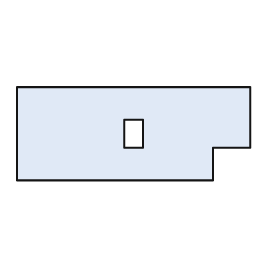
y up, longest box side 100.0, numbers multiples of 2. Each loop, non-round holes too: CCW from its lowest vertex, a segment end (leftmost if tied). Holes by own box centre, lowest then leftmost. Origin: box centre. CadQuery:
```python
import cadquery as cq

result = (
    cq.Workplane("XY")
    .moveTo(-50.0, -20.0)
    .lineTo(34.0, -20.0)
    .lineTo(34.0, -6.0)
    .lineTo(50.0, -6.0)
    .lineTo(50.0, 20.0)
    .lineTo(-50.0, 20.0)
    .close()
    .moveTo(-4.0, -6.0)
    .lineTo(4.0, -6.0)
    .lineTo(4.0, 6.0)
    .lineTo(-4.0, 6.0)
    .close()
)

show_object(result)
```